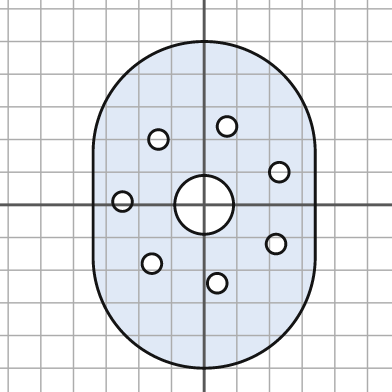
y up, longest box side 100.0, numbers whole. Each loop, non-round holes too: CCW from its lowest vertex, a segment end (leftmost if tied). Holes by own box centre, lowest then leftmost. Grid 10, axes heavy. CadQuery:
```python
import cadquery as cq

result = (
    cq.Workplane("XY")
    .moveTo(-34.0, -16.0)
    .threePointArc((0.0, -50.0), (34.0, -16.0))
    .lineTo(34.0, 16.0)
    .threePointArc((0.0, 50.0), (-34.0, 16.0))
    .close()
    .moveTo(4.0, -24.0)
    .circle(3.0)
    .moveTo(-16.0, -18.0)
    .circle(3.0)
    .moveTo(22.0, -12.0)
    .circle(3.0)
    .moveTo(0.0, 0.0)
    .circle(9.0)
    .moveTo(-25.0, 1.0)
    .circle(3.0)
    .moveTo(23.0, 10.0)
    .circle(3.0)
    .moveTo(-14.0, 20.0)
    .circle(3.0)
    .moveTo(7.0, 24.0)
    .circle(3.0)
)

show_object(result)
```